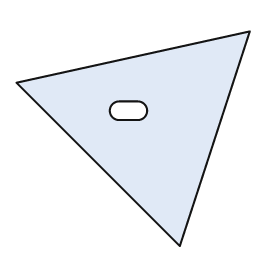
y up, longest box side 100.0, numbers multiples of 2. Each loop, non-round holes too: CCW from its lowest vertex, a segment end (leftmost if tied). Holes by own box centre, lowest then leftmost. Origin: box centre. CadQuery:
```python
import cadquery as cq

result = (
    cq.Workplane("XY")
    .moveTo(20.0, -46.0)
    .lineTo(50.0, 46.0)
    .lineTo(-50.0, 24.0)
    .close()
    .moveTo(-6.0, 8.0)
    .lineTo(2.0, 8.0)
    .threePointArc((6.0, 12.0), (2.0, 16.0))
    .lineTo(-6.0, 16.0)
    .threePointArc((-10.0, 12.0), (-6.0, 8.0))
    .close()
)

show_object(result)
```